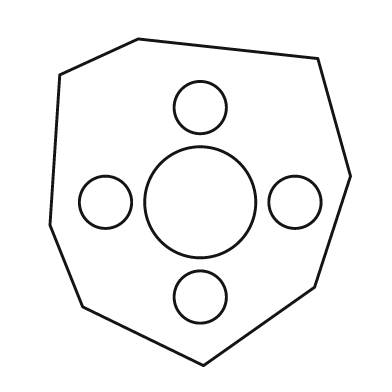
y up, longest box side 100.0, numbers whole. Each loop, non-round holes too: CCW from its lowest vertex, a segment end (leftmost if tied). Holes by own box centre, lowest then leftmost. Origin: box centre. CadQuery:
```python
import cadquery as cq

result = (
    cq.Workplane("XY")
    .moveTo(1.0, -50.0)
    .lineTo(35.0, -26.0)
    .lineTo(46.0, 8.0)
    .lineTo(36.0, 44.0)
    .lineTo(-19.0, 50.0)
    .lineTo(-43.0, 39.0)
    .lineTo(-46.0, -7.0)
    .lineTo(-36.0, -32.0)
    .close()
    .moveTo(0.0, -29.0)
    .circle(8.0)
    .moveTo(-29.0, 0.0)
    .circle(8.0)
    .moveTo(0.0, 0.0)
    .circle(17.0)
    .moveTo(29.0, 0.0)
    .circle(8.0)
    .moveTo(0.0, 29.0)
    .circle(8.0)
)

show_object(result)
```